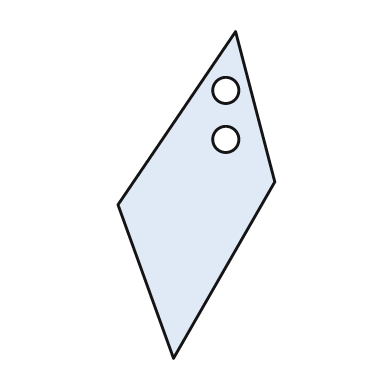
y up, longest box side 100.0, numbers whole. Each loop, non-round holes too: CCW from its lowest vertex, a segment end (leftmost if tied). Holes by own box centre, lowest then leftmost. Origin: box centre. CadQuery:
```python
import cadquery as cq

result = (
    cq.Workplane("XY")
    .moveTo(-7.0, -50.0)
    .lineTo(24.0, 4.0)
    .lineTo(12.0, 50.0)
    .lineTo(-24.0, -3.0)
    .close()
    .moveTo(9.0, 17.0)
    .circle(4.0)
    .moveTo(9.0, 32.0)
    .circle(4.0)
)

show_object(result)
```